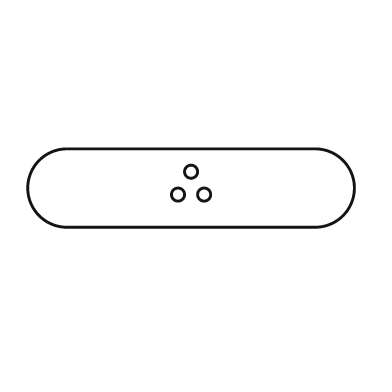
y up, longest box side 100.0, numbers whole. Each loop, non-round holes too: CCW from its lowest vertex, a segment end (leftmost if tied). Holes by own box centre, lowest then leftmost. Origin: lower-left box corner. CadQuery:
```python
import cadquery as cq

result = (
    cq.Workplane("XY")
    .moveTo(12.0, 0.0)
    .lineTo(88.0, 0.0)
    .threePointArc((100.0, 12.0), (88.0, 24.0))
    .lineTo(12.0, 24.0)
    .threePointArc((0.0, 12.0), (12.0, 0.0))
    .close()
    .moveTo(46.0, 10.0)
    .circle(2.0)
    .moveTo(54.0, 10.0)
    .circle(2.0)
    .moveTo(50.0, 17.0)
    .circle(2.0)
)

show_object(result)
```